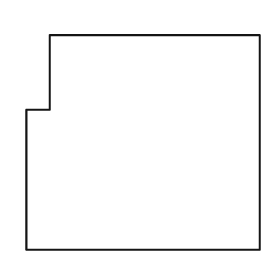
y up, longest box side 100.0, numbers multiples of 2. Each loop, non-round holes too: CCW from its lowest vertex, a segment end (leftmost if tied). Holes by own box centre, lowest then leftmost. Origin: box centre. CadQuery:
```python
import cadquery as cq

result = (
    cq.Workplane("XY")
    .moveTo(-50.0, -46.0)
    .lineTo(50.0, -46.0)
    .lineTo(50.0, 46.0)
    .lineTo(-40.0, 46.0)
    .lineTo(-40.0, 14.0)
    .lineTo(-50.0, 14.0)
    .close()
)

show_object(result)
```